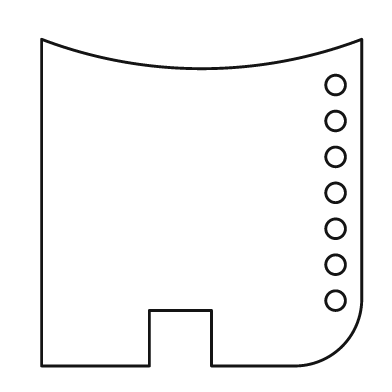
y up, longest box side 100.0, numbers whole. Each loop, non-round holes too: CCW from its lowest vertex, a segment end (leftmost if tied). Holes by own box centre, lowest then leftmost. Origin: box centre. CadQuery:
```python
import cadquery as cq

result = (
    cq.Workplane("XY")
    .moveTo(-49.0, -50.0)
    .lineTo(-16.0, -50.0)
    .lineTo(-16.0, -33.0)
    .lineTo(3.0, -33.0)
    .lineTo(3.0, -50.0)
    .lineTo(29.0, -50.0)
    .threePointArc((43.0, -44.0), (49.0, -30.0))
    .lineTo(49.0, 50.0)
    .threePointArc((0.0, 41.0), (-49.0, 50.0))
    .close()
    .moveTo(41.0, -30.0)
    .circle(3.0)
    .moveTo(41.0, -19.0)
    .circle(3.0)
    .moveTo(41.0, -8.0)
    .circle(3.0)
    .moveTo(41.0, 3.0)
    .circle(3.0)
    .moveTo(41.0, 14.0)
    .circle(3.0)
    .moveTo(41.0, 25.0)
    .circle(3.0)
    .moveTo(41.0, 36.0)
    .circle(3.0)
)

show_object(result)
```